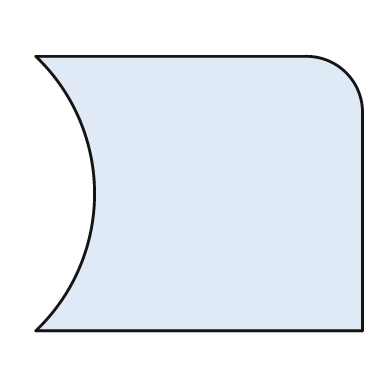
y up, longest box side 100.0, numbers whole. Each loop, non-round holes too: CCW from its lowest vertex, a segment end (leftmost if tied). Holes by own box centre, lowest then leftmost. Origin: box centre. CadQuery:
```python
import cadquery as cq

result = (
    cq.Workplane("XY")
    .moveTo(-50.0, -42.0)
    .lineTo(50.0, -42.0)
    .lineTo(50.0, 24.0)
    .threePointArc((45.0, 37.0), (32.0, 42.0))
    .lineTo(-50.0, 42.0)
    .threePointArc((-32.0, 0.0), (-50.0, -42.0))
    .close()
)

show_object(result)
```